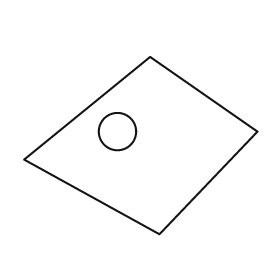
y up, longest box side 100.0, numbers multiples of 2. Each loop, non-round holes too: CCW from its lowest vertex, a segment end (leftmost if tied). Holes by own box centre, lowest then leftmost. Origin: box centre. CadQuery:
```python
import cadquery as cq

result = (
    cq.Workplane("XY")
    .moveTo(8.0, -38.0)
    .lineTo(50.0, 6.0)
    .lineTo(4.0, 38.0)
    .lineTo(-50.0, -6.0)
    .close()
    .moveTo(-10.0, 6.0)
    .circle(8.0)
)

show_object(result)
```